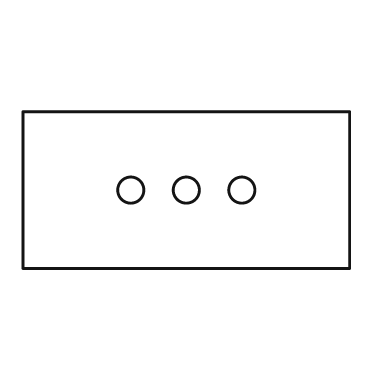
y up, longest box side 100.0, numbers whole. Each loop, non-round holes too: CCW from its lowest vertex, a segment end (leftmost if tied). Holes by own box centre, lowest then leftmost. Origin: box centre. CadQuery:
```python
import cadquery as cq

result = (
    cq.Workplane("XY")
    .moveTo(-50.0, -24.0)
    .lineTo(50.0, -24.0)
    .lineTo(50.0, 24.0)
    .lineTo(-50.0, 24.0)
    .close()
    .moveTo(-17.0, 0.0)
    .circle(4.0)
    .moveTo(0.0, 0.0)
    .circle(4.0)
    .moveTo(17.0, 0.0)
    .circle(4.0)
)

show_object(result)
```